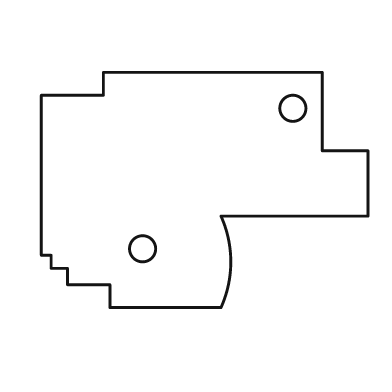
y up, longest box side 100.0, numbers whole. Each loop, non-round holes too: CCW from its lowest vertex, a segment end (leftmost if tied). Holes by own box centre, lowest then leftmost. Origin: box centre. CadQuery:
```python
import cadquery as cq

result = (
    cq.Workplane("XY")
    .moveTo(-29.0, -36.0)
    .lineTo(5.0, -36.0)
    .threePointArc((8.0, -22.0), (5.0, -8.0))
    .lineTo(50.0, -8.0)
    .lineTo(50.0, 12.0)
    .lineTo(36.0, 12.0)
    .lineTo(36.0, 36.0)
    .lineTo(-31.0, 36.0)
    .lineTo(-31.0, 29.0)
    .lineTo(-50.0, 29.0)
    .lineTo(-50.0, -20.0)
    .lineTo(-47.0, -20.0)
    .lineTo(-47.0, -24.0)
    .lineTo(-42.0, -24.0)
    .lineTo(-42.0, -29.0)
    .lineTo(-29.0, -29.0)
    .close()
    .moveTo(-19.0, -18.0)
    .circle(4.0)
    .moveTo(27.0, 25.0)
    .circle(4.0)
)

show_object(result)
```